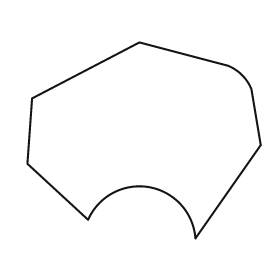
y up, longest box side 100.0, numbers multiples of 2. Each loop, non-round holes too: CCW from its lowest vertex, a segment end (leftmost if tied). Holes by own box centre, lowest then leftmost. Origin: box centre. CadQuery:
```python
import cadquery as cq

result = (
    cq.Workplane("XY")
    .moveTo(22.0, -42.0)
    .lineTo(50.0, -2.0)
    .lineTo(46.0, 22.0)
    .threePointArc((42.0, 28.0), (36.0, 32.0))
    .lineTo(-2.0, 42.0)
    .lineTo(-48.0, 18.0)
    .lineTo(-50.0, -10.0)
    .lineTo(-24.0, -34.0)
    .threePointArc((2.0, -20.0), (22.0, -42.0))
    .close()
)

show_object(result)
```